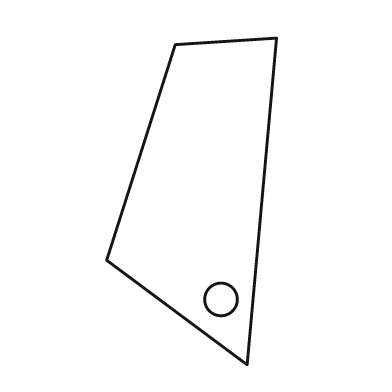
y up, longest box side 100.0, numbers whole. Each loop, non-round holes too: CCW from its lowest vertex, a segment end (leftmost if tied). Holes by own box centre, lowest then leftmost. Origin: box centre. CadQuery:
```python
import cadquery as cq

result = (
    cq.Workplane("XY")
    .moveTo(17.0, -50.0)
    .lineTo(26.0, 50.0)
    .lineTo(-5.0, 48.0)
    .lineTo(-26.0, -18.0)
    .close()
    .moveTo(9.0, -30.0)
    .circle(5.0)
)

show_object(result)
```